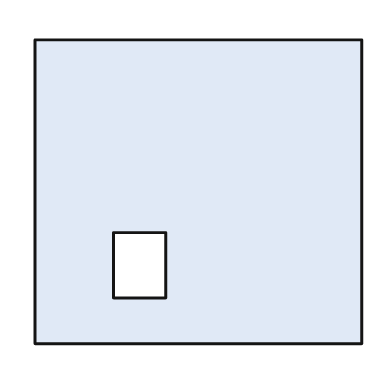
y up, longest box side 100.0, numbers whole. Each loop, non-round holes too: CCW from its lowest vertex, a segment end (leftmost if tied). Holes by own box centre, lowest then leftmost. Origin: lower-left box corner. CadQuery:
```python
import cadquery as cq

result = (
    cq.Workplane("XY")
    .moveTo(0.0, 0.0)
    .lineTo(100.0, 0.0)
    .lineTo(100.0, 93.0)
    .lineTo(0.0, 93.0)
    .close()
    .moveTo(24.0, 14.0)
    .lineTo(40.0, 14.0)
    .lineTo(40.0, 34.0)
    .lineTo(24.0, 34.0)
    .close()
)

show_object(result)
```